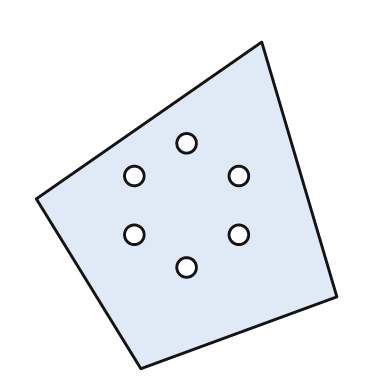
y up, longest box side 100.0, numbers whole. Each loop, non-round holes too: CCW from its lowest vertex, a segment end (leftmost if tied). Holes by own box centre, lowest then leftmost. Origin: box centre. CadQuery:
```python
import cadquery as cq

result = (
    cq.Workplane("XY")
    .moveTo(-14.0, -50.0)
    .lineTo(46.0, -28.0)
    .lineTo(23.0, 50.0)
    .lineTo(-46.0, 2.0)
    .close()
    .moveTo(0.0, -19.0)
    .circle(3.0)
    .moveTo(-16.0, -9.0)
    .circle(3.0)
    .moveTo(16.0, -9.0)
    .circle(3.0)
    .moveTo(-16.0, 9.0)
    .circle(3.0)
    .moveTo(16.0, 9.0)
    .circle(3.0)
    .moveTo(0.0, 19.0)
    .circle(3.0)
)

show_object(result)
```